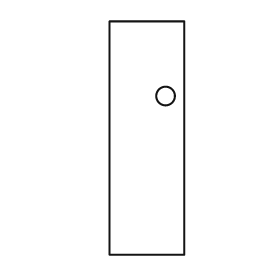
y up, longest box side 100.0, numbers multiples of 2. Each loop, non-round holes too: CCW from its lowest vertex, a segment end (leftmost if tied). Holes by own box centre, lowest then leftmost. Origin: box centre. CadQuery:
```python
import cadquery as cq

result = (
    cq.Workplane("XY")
    .moveTo(-16.0, -50.0)
    .lineTo(16.0, -50.0)
    .lineTo(16.0, 50.0)
    .lineTo(-16.0, 50.0)
    .close()
    .moveTo(8.0, 18.0)
    .circle(4.0)
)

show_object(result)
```